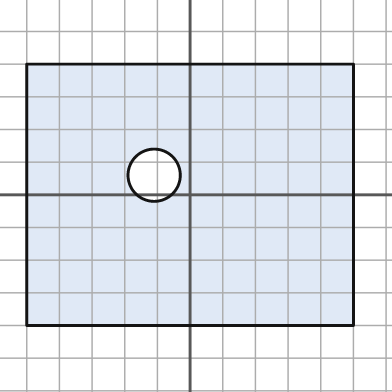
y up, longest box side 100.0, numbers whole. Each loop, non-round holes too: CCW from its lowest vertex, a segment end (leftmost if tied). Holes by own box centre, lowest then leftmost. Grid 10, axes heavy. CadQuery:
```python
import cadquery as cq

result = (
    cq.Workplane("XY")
    .moveTo(-50.0, -40.0)
    .lineTo(50.0, -40.0)
    .lineTo(50.0, 40.0)
    .lineTo(-50.0, 40.0)
    .close()
    .moveTo(-11.0, 6.0)
    .circle(8.0)
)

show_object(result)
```